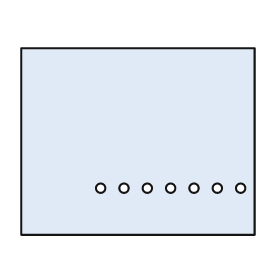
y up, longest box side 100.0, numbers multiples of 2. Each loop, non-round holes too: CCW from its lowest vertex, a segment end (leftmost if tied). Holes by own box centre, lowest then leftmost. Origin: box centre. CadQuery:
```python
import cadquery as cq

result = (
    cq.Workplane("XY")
    .moveTo(-50.0, -40.0)
    .lineTo(50.0, -40.0)
    .lineTo(50.0, 40.0)
    .lineTo(-50.0, 40.0)
    .close()
    .moveTo(-16.0, -20.0)
    .circle(2.0)
    .moveTo(-6.0, -20.0)
    .circle(2.0)
    .moveTo(4.0, -20.0)
    .circle(2.0)
    .moveTo(14.0, -20.0)
    .circle(2.0)
    .moveTo(24.0, -20.0)
    .circle(2.0)
    .moveTo(34.0, -20.0)
    .circle(2.0)
    .moveTo(44.0, -20.0)
    .circle(2.0)
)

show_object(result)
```